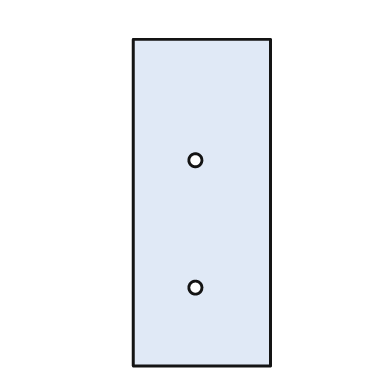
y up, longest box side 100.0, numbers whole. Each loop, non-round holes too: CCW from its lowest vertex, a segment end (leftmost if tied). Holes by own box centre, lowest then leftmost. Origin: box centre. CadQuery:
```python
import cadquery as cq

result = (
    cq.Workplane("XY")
    .moveTo(-21.0, -50.0)
    .lineTo(21.0, -50.0)
    .lineTo(21.0, 50.0)
    .lineTo(-21.0, 50.0)
    .close()
    .moveTo(-2.0, -26.0)
    .circle(2.0)
    .moveTo(-2.0, 13.0)
    .circle(2.0)
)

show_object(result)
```